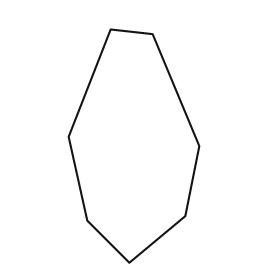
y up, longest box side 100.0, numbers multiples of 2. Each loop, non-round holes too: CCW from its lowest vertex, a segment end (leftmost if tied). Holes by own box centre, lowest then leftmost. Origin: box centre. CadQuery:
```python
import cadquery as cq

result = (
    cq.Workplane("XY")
    .moveTo(-2.0, -50.0)
    .lineTo(22.0, -30.0)
    .lineTo(28.0, 0.0)
    .lineTo(8.0, 48.0)
    .lineTo(-10.0, 50.0)
    .lineTo(-28.0, 4.0)
    .lineTo(-20.0, -32.0)
    .close()
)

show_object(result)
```